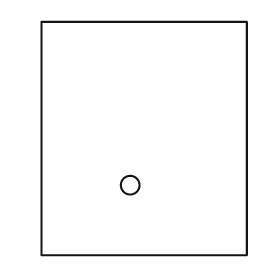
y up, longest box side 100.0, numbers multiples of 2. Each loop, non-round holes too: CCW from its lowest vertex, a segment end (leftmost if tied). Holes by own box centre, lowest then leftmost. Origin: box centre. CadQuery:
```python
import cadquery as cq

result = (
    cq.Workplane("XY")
    .moveTo(-44.0, -50.0)
    .lineTo(44.0, -50.0)
    .lineTo(44.0, 50.0)
    .lineTo(-44.0, 50.0)
    .close()
    .moveTo(-6.0, -20.0)
    .circle(4.0)
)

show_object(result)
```